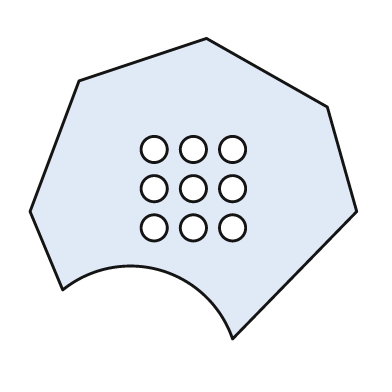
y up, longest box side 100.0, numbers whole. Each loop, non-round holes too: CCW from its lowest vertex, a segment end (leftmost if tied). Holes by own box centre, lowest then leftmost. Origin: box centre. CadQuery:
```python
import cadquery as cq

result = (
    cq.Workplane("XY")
    .moveTo(12.0, -46.0)
    .lineTo(50.0, -7.0)
    .lineTo(41.0, 25.0)
    .lineTo(4.0, 46.0)
    .lineTo(-35.0, 33.0)
    .lineTo(-50.0, -7.0)
    .lineTo(-40.0, -31.0)
    .threePointArc((-10.0, -25.0), (12.0, -46.0))
    .close()
    .moveTo(-12.0, -12.0)
    .circle(4.0)
    .moveTo(0.0, -12.0)
    .circle(4.0)
    .moveTo(12.0, -12.0)
    .circle(4.0)
    .moveTo(-12.0, 0.0)
    .circle(4.0)
    .moveTo(0.0, 0.0)
    .circle(4.0)
    .moveTo(12.0, 0.0)
    .circle(4.0)
    .moveTo(-12.0, 12.0)
    .circle(4.0)
    .moveTo(0.0, 12.0)
    .circle(4.0)
    .moveTo(12.0, 12.0)
    .circle(4.0)
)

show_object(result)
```